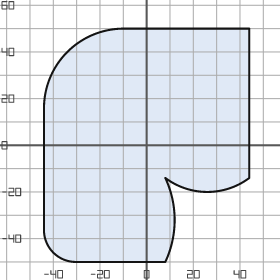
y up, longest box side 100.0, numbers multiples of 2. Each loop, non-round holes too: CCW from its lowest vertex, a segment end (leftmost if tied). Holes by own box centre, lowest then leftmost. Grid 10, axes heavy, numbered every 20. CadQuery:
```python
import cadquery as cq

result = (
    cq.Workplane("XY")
    .moveTo(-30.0, -50.0)
    .lineTo(8.0, -50.0)
    .threePointArc((12.0, -32.0), (8.0, -14.0))
    .threePointArc((26.0, -20.0), (44.0, -14.0))
    .lineTo(44.0, 50.0)
    .lineTo(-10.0, 50.0)
    .threePointArc((-34.0, 40.0), (-44.0, 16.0))
    .lineTo(-44.0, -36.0)
    .threePointArc((-40.0, -46.0), (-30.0, -50.0))
    .close()
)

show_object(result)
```